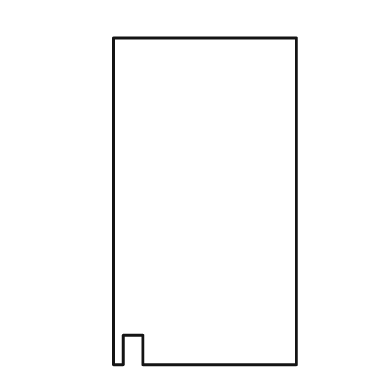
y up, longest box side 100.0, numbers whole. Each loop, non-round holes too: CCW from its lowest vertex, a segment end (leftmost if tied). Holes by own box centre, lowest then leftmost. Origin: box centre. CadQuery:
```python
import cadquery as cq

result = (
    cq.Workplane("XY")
    .moveTo(-28.0, -50.0)
    .lineTo(-25.0, -50.0)
    .lineTo(-25.0, -41.0)
    .lineTo(-19.0, -41.0)
    .lineTo(-19.0, -50.0)
    .lineTo(28.0, -50.0)
    .lineTo(28.0, 50.0)
    .lineTo(-28.0, 50.0)
    .close()
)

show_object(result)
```